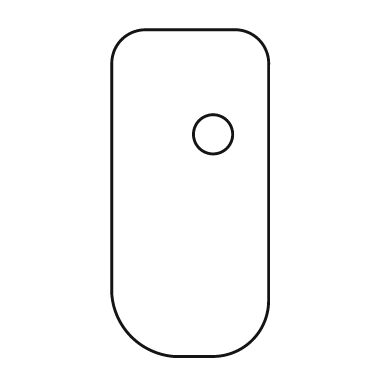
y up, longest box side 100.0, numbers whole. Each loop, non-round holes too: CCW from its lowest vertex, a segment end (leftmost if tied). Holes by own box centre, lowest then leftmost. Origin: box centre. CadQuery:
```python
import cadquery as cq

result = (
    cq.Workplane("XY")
    .moveTo(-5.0, -50.0)
    .lineTo(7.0, -50.0)
    .threePointArc((19.0, -45.0), (24.0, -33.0))
    .lineTo(24.0, 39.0)
    .threePointArc((21.0, 47.0), (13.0, 50.0))
    .lineTo(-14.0, 50.0)
    .threePointArc((-21.0, 47.0), (-24.0, 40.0))
    .lineTo(-24.0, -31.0)
    .threePointArc((-18.0, -44.0), (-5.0, -50.0))
    .close()
    .moveTo(7.0, 18.0)
    .circle(6.0)
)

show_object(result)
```